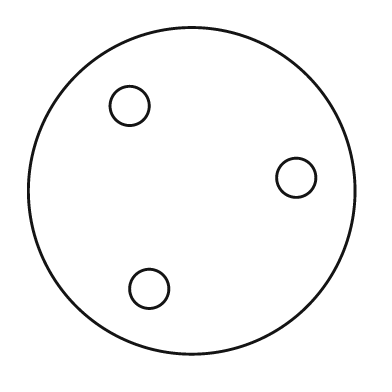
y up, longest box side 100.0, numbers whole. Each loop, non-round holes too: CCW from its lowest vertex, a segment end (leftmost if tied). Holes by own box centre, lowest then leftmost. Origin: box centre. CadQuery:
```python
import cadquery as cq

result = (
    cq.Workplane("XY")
    .moveTo(0.0, 0.0)
    .circle(50.0)
    .moveTo(-13.0, -30.0)
    .circle(6.0)
    .moveTo(32.0, 4.0)
    .circle(6.0)
    .moveTo(-19.0, 26.0)
    .circle(6.0)
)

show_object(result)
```